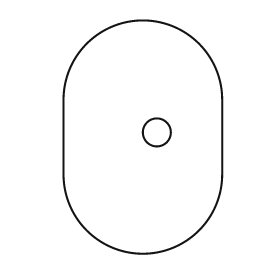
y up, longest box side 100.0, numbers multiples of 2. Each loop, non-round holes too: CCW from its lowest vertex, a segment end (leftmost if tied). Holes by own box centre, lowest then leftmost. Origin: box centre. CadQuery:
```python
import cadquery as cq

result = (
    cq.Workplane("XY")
    .moveTo(-34.0, -16.0)
    .threePointArc((0.0, -50.0), (34.0, -16.0))
    .lineTo(34.0, 16.0)
    .threePointArc((0.0, 50.0), (-34.0, 16.0))
    .close()
    .moveTo(6.0, 2.0)
    .circle(6.0)
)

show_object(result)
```